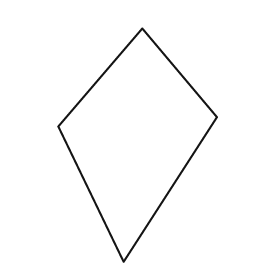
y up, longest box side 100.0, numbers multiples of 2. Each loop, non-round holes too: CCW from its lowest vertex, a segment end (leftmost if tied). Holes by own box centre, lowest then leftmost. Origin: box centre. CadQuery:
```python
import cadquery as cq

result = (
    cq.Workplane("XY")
    .moveTo(-6.0, -50.0)
    .lineTo(34.0, 12.0)
    .lineTo(2.0, 50.0)
    .lineTo(-34.0, 8.0)
    .close()
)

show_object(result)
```